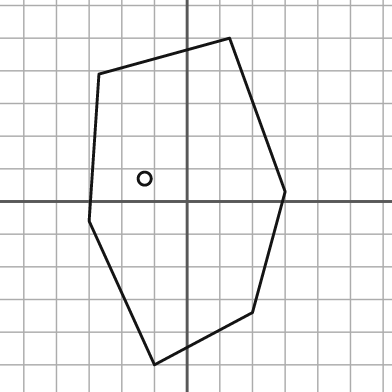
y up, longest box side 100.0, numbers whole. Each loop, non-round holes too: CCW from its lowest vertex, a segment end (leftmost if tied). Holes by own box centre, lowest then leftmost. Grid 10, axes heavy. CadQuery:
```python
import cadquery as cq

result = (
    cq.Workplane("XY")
    .moveTo(-10.0, -50.0)
    .lineTo(20.0, -34.0)
    .lineTo(30.0, 3.0)
    .lineTo(13.0, 50.0)
    .lineTo(-27.0, 39.0)
    .lineTo(-30.0, -6.0)
    .close()
    .moveTo(-13.0, 7.0)
    .circle(2.0)
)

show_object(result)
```